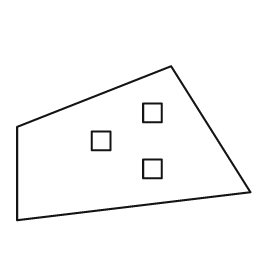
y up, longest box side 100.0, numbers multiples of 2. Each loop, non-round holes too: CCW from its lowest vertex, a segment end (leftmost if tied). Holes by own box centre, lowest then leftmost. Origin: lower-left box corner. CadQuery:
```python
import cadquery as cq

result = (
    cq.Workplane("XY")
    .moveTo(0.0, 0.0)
    .lineTo(100.0, 12.0)
    .lineTo(66.0, 66.0)
    .lineTo(0.0, 40.0)
    .close()
    .moveTo(54.0, 18.0)
    .lineTo(62.0, 18.0)
    .lineTo(62.0, 26.0)
    .lineTo(54.0, 26.0)
    .close()
    .moveTo(32.0, 30.0)
    .lineTo(40.0, 30.0)
    .lineTo(40.0, 38.0)
    .lineTo(32.0, 38.0)
    .close()
    .moveTo(54.0, 42.0)
    .lineTo(62.0, 42.0)
    .lineTo(62.0, 50.0)
    .lineTo(54.0, 50.0)
    .close()
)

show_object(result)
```